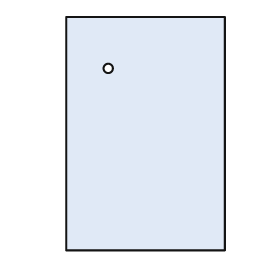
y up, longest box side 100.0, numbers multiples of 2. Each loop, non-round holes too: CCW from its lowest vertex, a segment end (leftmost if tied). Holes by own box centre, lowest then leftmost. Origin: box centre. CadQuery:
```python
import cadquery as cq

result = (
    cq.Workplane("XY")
    .moveTo(-34.0, -50.0)
    .lineTo(34.0, -50.0)
    .lineTo(34.0, 50.0)
    .lineTo(-34.0, 50.0)
    .close()
    .moveTo(-16.0, 28.0)
    .circle(2.0)
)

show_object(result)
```